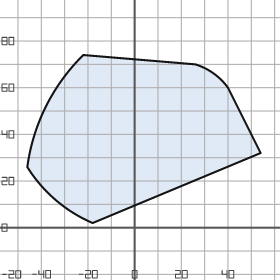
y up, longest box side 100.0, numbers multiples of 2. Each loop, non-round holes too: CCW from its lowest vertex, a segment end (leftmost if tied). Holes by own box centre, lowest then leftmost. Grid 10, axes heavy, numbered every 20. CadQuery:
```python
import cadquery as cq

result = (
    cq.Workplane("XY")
    .moveTo(-18.0, 2.0)
    .lineTo(54.0, 32.0)
    .lineTo(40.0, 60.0)
    .threePointArc((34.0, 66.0), (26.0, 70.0))
    .lineTo(-22.0, 74.0)
    .threePointArc((-38.0, 52.0), (-46.0, 26.0))
    .threePointArc((-34.0, 12.0), (-18.0, 2.0))
    .close()
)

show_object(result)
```